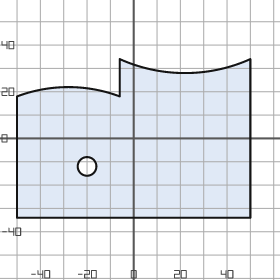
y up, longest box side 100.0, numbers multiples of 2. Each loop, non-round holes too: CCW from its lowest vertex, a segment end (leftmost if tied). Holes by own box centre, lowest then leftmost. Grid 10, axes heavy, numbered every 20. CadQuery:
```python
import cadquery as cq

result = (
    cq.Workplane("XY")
    .moveTo(-50.0, -34.0)
    .lineTo(50.0, -34.0)
    .lineTo(50.0, 34.0)
    .threePointArc((22.0, 28.0), (-6.0, 34.0))
    .lineTo(-6.0, 18.0)
    .threePointArc((-28.0, 22.0), (-50.0, 18.0))
    .close()
    .moveTo(-20.0, -12.0)
    .circle(4.0)
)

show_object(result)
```